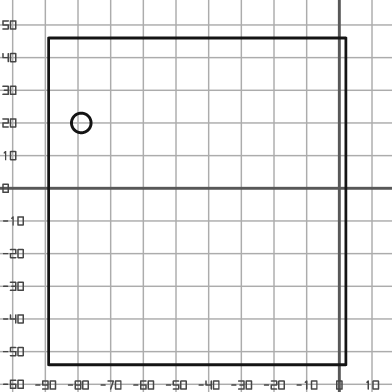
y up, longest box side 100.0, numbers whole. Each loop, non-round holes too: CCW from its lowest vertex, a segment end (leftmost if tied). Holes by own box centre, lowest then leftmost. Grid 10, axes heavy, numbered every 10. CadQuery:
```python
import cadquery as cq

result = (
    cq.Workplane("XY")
    .moveTo(-89.0, -54.0)
    .lineTo(2.0, -54.0)
    .lineTo(2.0, 46.0)
    .lineTo(-89.0, 46.0)
    .close()
    .moveTo(-79.0, 20.0)
    .circle(3.0)
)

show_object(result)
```